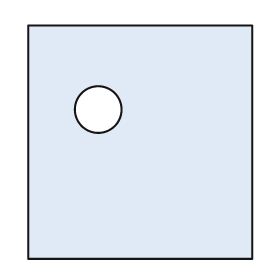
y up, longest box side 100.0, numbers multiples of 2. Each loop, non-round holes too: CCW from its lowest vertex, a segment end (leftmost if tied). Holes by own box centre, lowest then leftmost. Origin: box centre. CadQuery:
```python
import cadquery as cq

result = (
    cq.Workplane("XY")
    .moveTo(-48.0, -50.0)
    .lineTo(48.0, -50.0)
    .lineTo(48.0, 50.0)
    .lineTo(-48.0, 50.0)
    .close()
    .moveTo(-18.0, 14.0)
    .circle(10.0)
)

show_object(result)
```